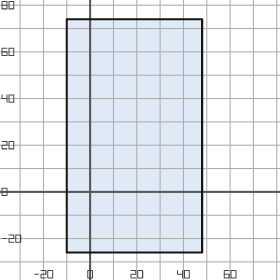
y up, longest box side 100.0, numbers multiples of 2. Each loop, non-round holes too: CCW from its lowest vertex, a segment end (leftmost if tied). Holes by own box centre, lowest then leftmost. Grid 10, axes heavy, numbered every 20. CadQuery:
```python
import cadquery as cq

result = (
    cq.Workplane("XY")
    .moveTo(-10.0, -26.0)
    .lineTo(48.0, -26.0)
    .lineTo(48.0, 74.0)
    .lineTo(-10.0, 74.0)
    .close()
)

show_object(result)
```